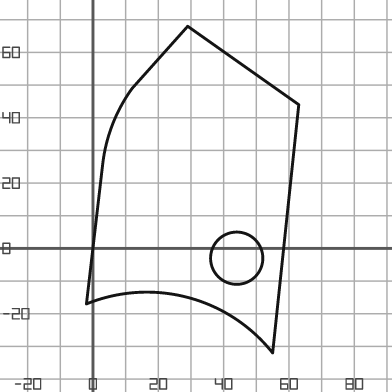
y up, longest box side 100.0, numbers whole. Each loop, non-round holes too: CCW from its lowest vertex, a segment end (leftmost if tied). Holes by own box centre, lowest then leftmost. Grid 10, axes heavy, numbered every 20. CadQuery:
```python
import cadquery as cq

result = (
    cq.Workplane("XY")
    .moveTo(55.0, -32.0)
    .lineTo(63.0, 44.0)
    .lineTo(29.0, 68.0)
    .lineTo(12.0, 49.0)
    .threePointArc((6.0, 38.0), (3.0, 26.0))
    .lineTo(-2.0, -17.0)
    .threePointArc((29.0, -15.0), (55.0, -32.0))
    .close()
    .moveTo(44.0, -3.0)
    .circle(8.0)
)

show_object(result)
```